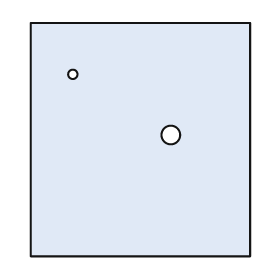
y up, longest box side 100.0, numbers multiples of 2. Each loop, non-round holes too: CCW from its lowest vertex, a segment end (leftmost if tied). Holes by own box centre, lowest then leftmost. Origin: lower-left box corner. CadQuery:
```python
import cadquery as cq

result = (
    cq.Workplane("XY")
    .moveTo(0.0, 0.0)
    .lineTo(94.0, 0.0)
    .lineTo(94.0, 100.0)
    .lineTo(0.0, 100.0)
    .close()
    .moveTo(60.0, 52.0)
    .circle(4.0)
    .moveTo(18.0, 78.0)
    .circle(2.0)
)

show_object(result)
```